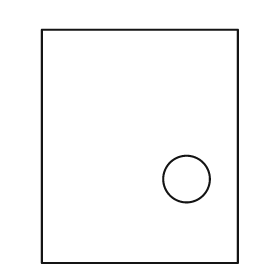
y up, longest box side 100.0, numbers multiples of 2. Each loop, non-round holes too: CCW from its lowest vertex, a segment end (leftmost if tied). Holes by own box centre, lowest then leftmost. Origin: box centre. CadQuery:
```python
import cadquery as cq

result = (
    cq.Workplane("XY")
    .moveTo(-42.0, -50.0)
    .lineTo(42.0, -50.0)
    .lineTo(42.0, 50.0)
    .lineTo(-42.0, 50.0)
    .close()
    .moveTo(20.0, -14.0)
    .circle(10.0)
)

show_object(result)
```